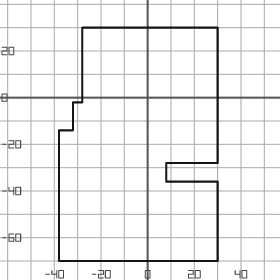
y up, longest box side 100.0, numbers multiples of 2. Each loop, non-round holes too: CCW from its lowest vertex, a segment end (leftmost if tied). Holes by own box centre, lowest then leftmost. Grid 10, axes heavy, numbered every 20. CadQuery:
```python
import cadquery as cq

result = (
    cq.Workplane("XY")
    .moveTo(-38.0, -70.0)
    .lineTo(30.0, -70.0)
    .lineTo(30.0, -36.0)
    .lineTo(8.0, -36.0)
    .lineTo(8.0, -28.0)
    .lineTo(30.0, -28.0)
    .lineTo(30.0, 30.0)
    .lineTo(-28.0, 30.0)
    .lineTo(-28.0, -2.0)
    .lineTo(-32.0, -2.0)
    .lineTo(-32.0, -14.0)
    .lineTo(-38.0, -14.0)
    .close()
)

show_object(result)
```